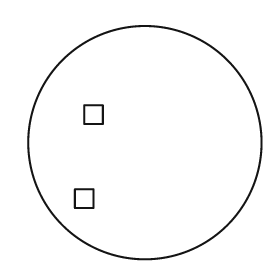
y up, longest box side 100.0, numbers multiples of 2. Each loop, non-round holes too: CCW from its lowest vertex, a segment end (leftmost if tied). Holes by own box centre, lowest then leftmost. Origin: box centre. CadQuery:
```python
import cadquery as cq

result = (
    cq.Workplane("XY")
    .moveTo(0.0, 0.0)
    .circle(50.0)
    .moveTo(-30.0, -28.0)
    .lineTo(-22.0, -28.0)
    .lineTo(-22.0, -20.0)
    .lineTo(-30.0, -20.0)
    .close()
    .moveTo(-26.0, 8.0)
    .lineTo(-18.0, 8.0)
    .lineTo(-18.0, 16.0)
    .lineTo(-26.0, 16.0)
    .close()
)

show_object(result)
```